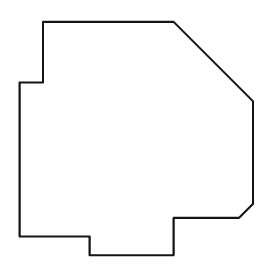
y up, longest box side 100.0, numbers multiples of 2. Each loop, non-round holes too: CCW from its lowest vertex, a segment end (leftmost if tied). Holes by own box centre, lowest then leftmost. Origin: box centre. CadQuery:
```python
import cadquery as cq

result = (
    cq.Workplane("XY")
    .moveTo(-20.0, -50.0)
    .lineTo(16.0, -50.0)
    .lineTo(16.0, -34.0)
    .lineTo(44.0, -34.0)
    .lineTo(50.0, -28.0)
    .lineTo(50.0, 16.0)
    .lineTo(16.0, 50.0)
    .lineTo(-40.0, 50.0)
    .lineTo(-40.0, 24.0)
    .lineTo(-50.0, 24.0)
    .lineTo(-50.0, -42.0)
    .lineTo(-20.0, -42.0)
    .close()
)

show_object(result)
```